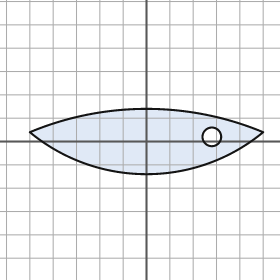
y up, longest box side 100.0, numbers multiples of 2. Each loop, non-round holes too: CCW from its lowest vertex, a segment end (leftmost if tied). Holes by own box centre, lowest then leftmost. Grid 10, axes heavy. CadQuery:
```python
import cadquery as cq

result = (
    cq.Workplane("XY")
    .moveTo(-50.0, 4.0)
    .threePointArc((0.0, -14.0), (50.0, 4.0))
    .threePointArc((0.0, 14.0), (-50.0, 4.0))
    .close()
    .moveTo(28.0, 2.0)
    .circle(4.0)
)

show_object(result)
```